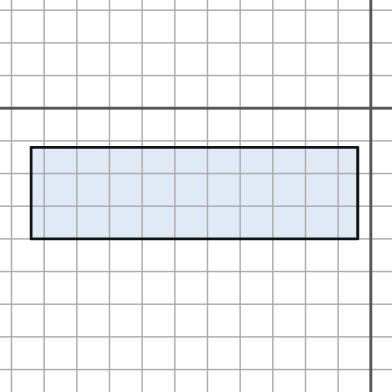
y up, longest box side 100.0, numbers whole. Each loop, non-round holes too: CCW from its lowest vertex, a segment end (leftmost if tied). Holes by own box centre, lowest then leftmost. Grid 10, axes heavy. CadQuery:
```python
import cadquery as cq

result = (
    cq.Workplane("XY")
    .moveTo(-104.0, -40.0)
    .lineTo(-4.0, -40.0)
    .lineTo(-4.0, -12.0)
    .lineTo(-104.0, -12.0)
    .close()
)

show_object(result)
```